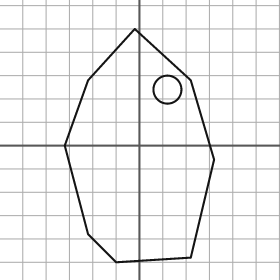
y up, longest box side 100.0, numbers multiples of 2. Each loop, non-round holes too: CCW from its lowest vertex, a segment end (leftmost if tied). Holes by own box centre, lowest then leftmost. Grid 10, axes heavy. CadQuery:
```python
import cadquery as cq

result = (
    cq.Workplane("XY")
    .moveTo(-10.0, -50.0)
    .lineTo(22.0, -48.0)
    .lineTo(32.0, -6.0)
    .lineTo(22.0, 28.0)
    .lineTo(-2.0, 50.0)
    .lineTo(-22.0, 28.0)
    .lineTo(-32.0, 0.0)
    .lineTo(-22.0, -38.0)
    .close()
    .moveTo(12.0, 24.0)
    .circle(6.0)
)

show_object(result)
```